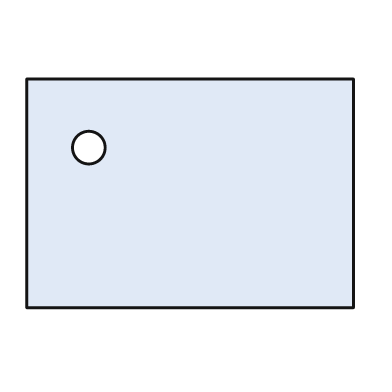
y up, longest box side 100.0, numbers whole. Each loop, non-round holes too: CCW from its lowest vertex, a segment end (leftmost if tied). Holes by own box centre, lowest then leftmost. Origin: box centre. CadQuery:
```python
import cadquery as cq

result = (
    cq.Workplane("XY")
    .moveTo(-50.0, -35.0)
    .lineTo(50.0, -35.0)
    .lineTo(50.0, 35.0)
    .lineTo(-50.0, 35.0)
    .close()
    .moveTo(-31.0, 14.0)
    .circle(5.0)
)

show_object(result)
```